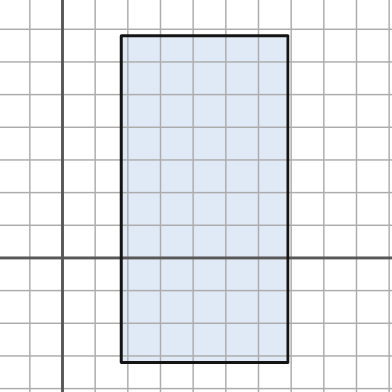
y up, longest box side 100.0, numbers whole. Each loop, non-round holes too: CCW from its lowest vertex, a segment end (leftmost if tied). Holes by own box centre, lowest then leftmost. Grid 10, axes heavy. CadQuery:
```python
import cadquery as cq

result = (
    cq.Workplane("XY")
    .moveTo(18.0, -32.0)
    .lineTo(69.0, -32.0)
    .lineTo(69.0, 68.0)
    .lineTo(18.0, 68.0)
    .close()
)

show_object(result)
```